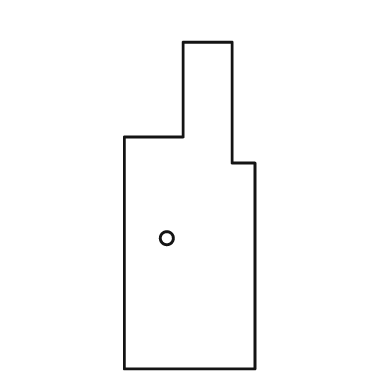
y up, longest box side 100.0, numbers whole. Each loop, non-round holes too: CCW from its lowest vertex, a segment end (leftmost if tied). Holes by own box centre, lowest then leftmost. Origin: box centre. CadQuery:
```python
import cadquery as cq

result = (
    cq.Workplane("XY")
    .moveTo(-20.0, -50.0)
    .lineTo(20.0, -50.0)
    .lineTo(20.0, 13.0)
    .lineTo(13.0, 13.0)
    .lineTo(13.0, 50.0)
    .lineTo(-2.0, 50.0)
    .lineTo(-2.0, 21.0)
    .lineTo(-20.0, 21.0)
    .close()
    .moveTo(-7.0, -10.0)
    .circle(2.0)
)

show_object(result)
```